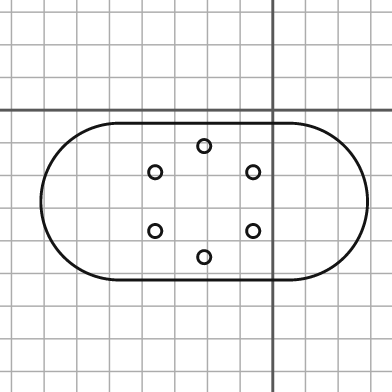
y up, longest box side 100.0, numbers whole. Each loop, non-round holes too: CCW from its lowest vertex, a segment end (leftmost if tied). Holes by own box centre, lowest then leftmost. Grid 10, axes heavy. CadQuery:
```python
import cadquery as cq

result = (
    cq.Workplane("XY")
    .moveTo(-47.0, -52.0)
    .lineTo(5.0, -52.0)
    .threePointArc((29.0, -28.0), (5.0, -4.0))
    .lineTo(-47.0, -4.0)
    .threePointArc((-71.0, -28.0), (-47.0, -52.0))
    .close()
    .moveTo(-21.0, -45.0)
    .circle(2.0)
    .moveTo(-36.0, -37.0)
    .circle(2.0)
    .moveTo(-6.0, -37.0)
    .circle(2.0)
    .moveTo(-36.0, -19.0)
    .circle(2.0)
    .moveTo(-6.0, -19.0)
    .circle(2.0)
    .moveTo(-21.0, -11.0)
    .circle(2.0)
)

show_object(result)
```